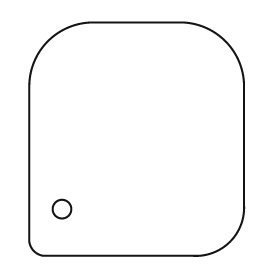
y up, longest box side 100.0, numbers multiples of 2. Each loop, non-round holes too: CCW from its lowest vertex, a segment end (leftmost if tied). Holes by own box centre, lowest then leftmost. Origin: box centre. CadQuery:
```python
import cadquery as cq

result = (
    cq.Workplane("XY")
    .moveTo(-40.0, -50.0)
    .lineTo(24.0, -50.0)
    .threePointArc((40.0, -44.0), (46.0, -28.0))
    .lineTo(46.0, 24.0)
    .threePointArc((38.0, 42.0), (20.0, 50.0))
    .lineTo(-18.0, 50.0)
    .threePointArc((-38.0, 42.0), (-46.0, 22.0))
    .lineTo(-46.0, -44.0)
    .threePointArc((-44.0, -48.0), (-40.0, -50.0))
    .close()
    .moveTo(-32.0, -30.0)
    .circle(4.0)
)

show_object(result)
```